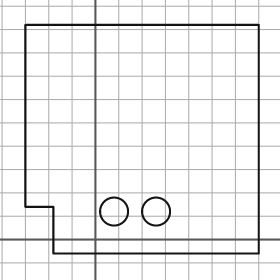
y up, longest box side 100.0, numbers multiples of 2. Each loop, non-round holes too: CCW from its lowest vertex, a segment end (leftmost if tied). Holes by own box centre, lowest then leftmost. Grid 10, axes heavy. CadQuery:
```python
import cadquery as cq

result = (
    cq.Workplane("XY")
    .moveTo(-18.0, -6.0)
    .lineTo(70.0, -6.0)
    .lineTo(70.0, 92.0)
    .lineTo(-30.0, 92.0)
    .lineTo(-30.0, 14.0)
    .lineTo(-18.0, 14.0)
    .close()
    .moveTo(8.0, 12.0)
    .circle(6.0)
    .moveTo(26.0, 12.0)
    .circle(6.0)
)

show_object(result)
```